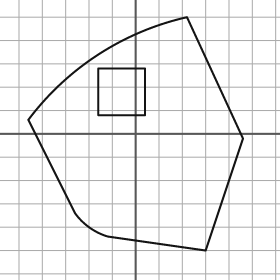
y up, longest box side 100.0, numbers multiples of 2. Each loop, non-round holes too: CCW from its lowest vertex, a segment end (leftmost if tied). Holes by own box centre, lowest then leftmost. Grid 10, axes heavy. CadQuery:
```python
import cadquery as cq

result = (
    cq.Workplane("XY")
    .moveTo(30.0, -50.0)
    .lineTo(46.0, -2.0)
    .lineTo(22.0, 50.0)
    .threePointArc((-16.0, 34.0), (-46.0, 6.0))
    .lineTo(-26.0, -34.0)
    .threePointArc((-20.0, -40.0), (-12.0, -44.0))
    .close()
    .moveTo(-16.0, 8.0)
    .lineTo(4.0, 8.0)
    .lineTo(4.0, 28.0)
    .lineTo(-16.0, 28.0)
    .close()
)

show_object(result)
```